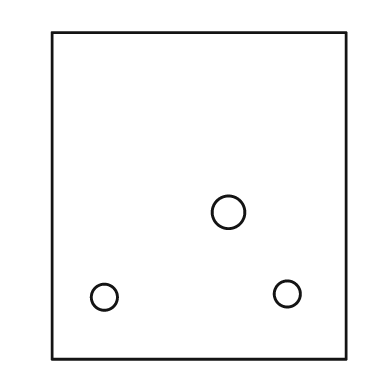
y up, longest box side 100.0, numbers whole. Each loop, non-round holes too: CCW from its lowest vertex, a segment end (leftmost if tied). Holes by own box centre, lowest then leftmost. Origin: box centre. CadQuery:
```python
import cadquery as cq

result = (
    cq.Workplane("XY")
    .moveTo(-45.0, -50.0)
    .lineTo(45.0, -50.0)
    .lineTo(45.0, 50.0)
    .lineTo(-45.0, 50.0)
    .close()
    .moveTo(-29.0, -31.0)
    .circle(4.0)
    .moveTo(27.0, -30.0)
    .circle(4.0)
    .moveTo(9.0, -5.0)
    .circle(5.0)
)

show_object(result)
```